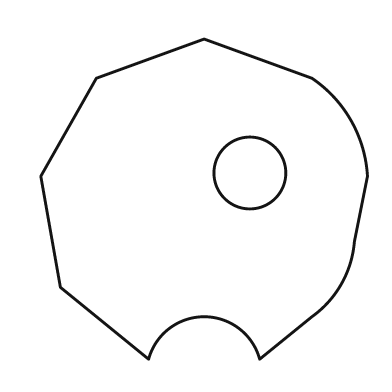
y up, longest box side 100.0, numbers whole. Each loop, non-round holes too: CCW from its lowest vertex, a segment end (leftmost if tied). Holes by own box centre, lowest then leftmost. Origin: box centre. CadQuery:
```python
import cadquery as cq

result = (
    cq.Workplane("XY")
    .moveTo(-17.0, -49.0)
    .threePointArc((0.0, -36.0), (17.0, -49.0))
    .lineTo(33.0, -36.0)
    .threePointArc((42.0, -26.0), (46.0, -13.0))
    .lineTo(50.0, 7.0)
    .threePointArc((45.0, 24.0), (33.0, 37.0))
    .lineTo(0.0, 49.0)
    .lineTo(-33.0, 37.0)
    .lineTo(-50.0, 7.0)
    .lineTo(-44.0, -27.0)
    .close()
    .moveTo(14.0, 8.0)
    .circle(11.0)
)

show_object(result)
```